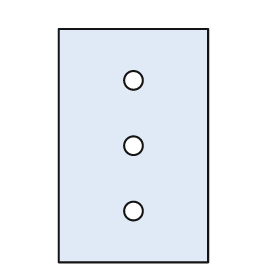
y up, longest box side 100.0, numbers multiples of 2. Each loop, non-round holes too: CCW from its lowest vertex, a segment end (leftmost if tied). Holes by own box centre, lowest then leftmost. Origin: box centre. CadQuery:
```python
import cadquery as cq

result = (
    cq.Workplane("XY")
    .moveTo(-32.0, -50.0)
    .lineTo(32.0, -50.0)
    .lineTo(32.0, 50.0)
    .lineTo(-32.0, 50.0)
    .close()
    .moveTo(0.0, -28.0)
    .circle(4.0)
    .moveTo(0.0, 0.0)
    .circle(4.0)
    .moveTo(0.0, 28.0)
    .circle(4.0)
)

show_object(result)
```